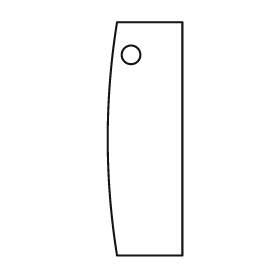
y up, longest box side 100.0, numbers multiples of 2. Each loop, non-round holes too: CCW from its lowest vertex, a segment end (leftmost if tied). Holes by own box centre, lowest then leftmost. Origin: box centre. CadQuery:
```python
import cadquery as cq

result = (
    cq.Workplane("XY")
    .moveTo(-12.0, -50.0)
    .lineTo(16.0, -50.0)
    .lineTo(16.0, 50.0)
    .lineTo(-12.0, 50.0)
    .threePointArc((-16.0, 0.0), (-12.0, -50.0))
    .close()
    .moveTo(-6.0, 36.0)
    .circle(4.0)
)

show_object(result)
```